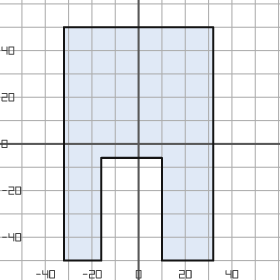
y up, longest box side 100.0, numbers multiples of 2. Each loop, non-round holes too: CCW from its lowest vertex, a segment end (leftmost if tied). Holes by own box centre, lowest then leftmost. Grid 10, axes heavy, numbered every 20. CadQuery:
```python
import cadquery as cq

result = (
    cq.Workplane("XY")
    .moveTo(-32.0, -50.0)
    .lineTo(-16.0, -50.0)
    .lineTo(-16.0, -6.0)
    .lineTo(10.0, -6.0)
    .lineTo(10.0, -50.0)
    .lineTo(32.0, -50.0)
    .lineTo(32.0, 50.0)
    .lineTo(-32.0, 50.0)
    .close()
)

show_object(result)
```